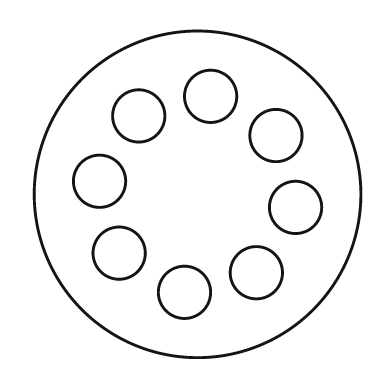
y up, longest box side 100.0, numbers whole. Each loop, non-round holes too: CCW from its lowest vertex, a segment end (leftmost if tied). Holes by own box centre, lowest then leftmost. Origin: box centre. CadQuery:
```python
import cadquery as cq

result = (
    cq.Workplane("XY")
    .moveTo(0.0, 0.0)
    .circle(50.0)
    .moveTo(-4.0, -30.0)
    .circle(8.0)
    .moveTo(18.0, -24.0)
    .circle(8.0)
    .moveTo(-24.0, -18.0)
    .circle(8.0)
    .moveTo(30.0, -4.0)
    .circle(8.0)
    .moveTo(-30.0, 4.0)
    .circle(8.0)
    .moveTo(24.0, 18.0)
    .circle(8.0)
    .moveTo(-18.0, 24.0)
    .circle(8.0)
    .moveTo(4.0, 30.0)
    .circle(8.0)
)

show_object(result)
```